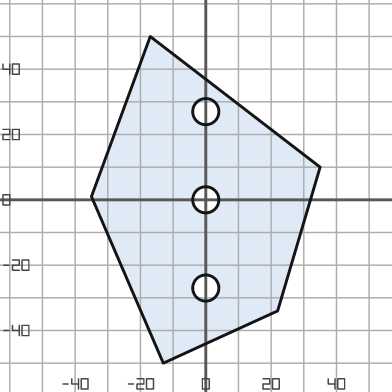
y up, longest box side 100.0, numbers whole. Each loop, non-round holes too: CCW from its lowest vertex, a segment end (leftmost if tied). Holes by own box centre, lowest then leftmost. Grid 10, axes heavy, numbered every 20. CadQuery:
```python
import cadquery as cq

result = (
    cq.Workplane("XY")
    .moveTo(-13.0, -50.0)
    .lineTo(22.0, -34.0)
    .lineTo(35.0, 10.0)
    .lineTo(-17.0, 50.0)
    .lineTo(-35.0, 1.0)
    .close()
    .moveTo(0.0, -27.0)
    .circle(4.0)
    .moveTo(0.0, 0.0)
    .circle(4.0)
    .moveTo(0.0, 27.0)
    .circle(4.0)
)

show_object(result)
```